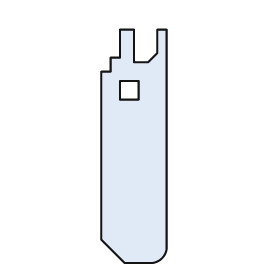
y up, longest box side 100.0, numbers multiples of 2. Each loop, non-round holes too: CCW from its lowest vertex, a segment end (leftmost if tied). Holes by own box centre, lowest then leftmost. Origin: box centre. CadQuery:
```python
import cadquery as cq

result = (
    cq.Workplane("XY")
    .moveTo(-4.0, -50.0)
    .lineTo(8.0, -50.0)
    .threePointArc((12.0, -48.0), (14.0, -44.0))
    .lineTo(14.0, 50.0)
    .lineTo(10.0, 50.0)
    .lineTo(10.0, 40.0)
    .lineTo(6.0, 36.0)
    .lineTo(0.0, 36.0)
    .lineTo(0.0, 50.0)
    .lineTo(-6.0, 50.0)
    .lineTo(-6.0, 38.0)
    .lineTo(-10.0, 38.0)
    .lineTo(-10.0, 32.0)
    .lineTo(-14.0, 32.0)
    .lineTo(-14.0, -40.0)
    .close()
    .moveTo(-6.0, 20.0)
    .lineTo(2.0, 20.0)
    .lineTo(2.0, 28.0)
    .lineTo(-6.0, 28.0)
    .close()
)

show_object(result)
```